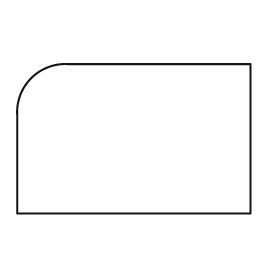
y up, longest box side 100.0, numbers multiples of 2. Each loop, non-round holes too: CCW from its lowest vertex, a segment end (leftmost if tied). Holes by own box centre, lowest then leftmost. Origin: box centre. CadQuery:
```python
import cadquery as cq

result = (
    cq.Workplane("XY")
    .moveTo(-50.0, -32.0)
    .lineTo(50.0, -32.0)
    .lineTo(50.0, 32.0)
    .lineTo(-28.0, 32.0)
    .threePointArc((-44.0, 26.0), (-50.0, 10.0))
    .close()
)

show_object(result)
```